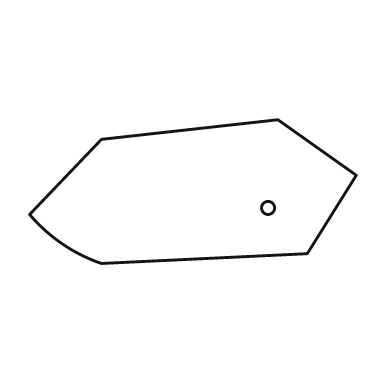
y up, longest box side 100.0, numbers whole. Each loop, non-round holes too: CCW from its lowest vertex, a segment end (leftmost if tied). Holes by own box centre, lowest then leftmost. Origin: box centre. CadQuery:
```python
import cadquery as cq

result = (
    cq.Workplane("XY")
    .moveTo(-28.0, -22.0)
    .lineTo(35.0, -19.0)
    .lineTo(50.0, 5.0)
    .lineTo(26.0, 22.0)
    .lineTo(-28.0, 16.0)
    .lineTo(-50.0, -7.0)
    .threePointArc((-40.0, -16.0), (-28.0, -22.0))
    .close()
    .moveTo(23.0, -5.0)
    .circle(2.0)
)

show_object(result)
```